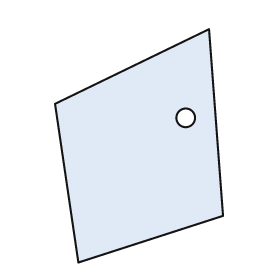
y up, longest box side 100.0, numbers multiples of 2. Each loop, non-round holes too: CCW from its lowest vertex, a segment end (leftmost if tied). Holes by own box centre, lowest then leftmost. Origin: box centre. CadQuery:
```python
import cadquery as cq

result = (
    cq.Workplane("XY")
    .moveTo(-26.0, -50.0)
    .lineTo(36.0, -30.0)
    .lineTo(30.0, 50.0)
    .lineTo(-36.0, 18.0)
    .close()
    .moveTo(20.0, 12.0)
    .circle(4.0)
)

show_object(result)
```